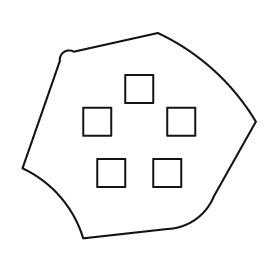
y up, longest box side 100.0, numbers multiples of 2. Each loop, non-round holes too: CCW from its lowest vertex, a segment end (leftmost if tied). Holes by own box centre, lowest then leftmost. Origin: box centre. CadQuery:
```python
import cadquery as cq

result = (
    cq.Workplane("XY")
    .moveTo(-24.0, -44.0)
    .lineTo(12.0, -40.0)
    .threePointArc((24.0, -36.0), (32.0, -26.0))
    .lineTo(50.0, 6.0)
    .threePointArc((32.0, 28.0), (8.0, 44.0))
    .lineTo(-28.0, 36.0)
    .threePointArc((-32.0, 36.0), (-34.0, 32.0))
    .lineTo(-50.0, -14.0)
    .threePointArc((-34.0, -26.0), (-24.0, -44.0))
    .close()
    .moveTo(-18.0, -22.0)
    .lineTo(-6.0, -22.0)
    .lineTo(-6.0, -10.0)
    .lineTo(-18.0, -10.0)
    .close()
    .moveTo(6.0, -22.0)
    .lineTo(18.0, -22.0)
    .lineTo(18.0, -10.0)
    .lineTo(6.0, -10.0)
    .close()
    .moveTo(-24.0, 0.0)
    .lineTo(-12.0, 0.0)
    .lineTo(-12.0, 12.0)
    .lineTo(-24.0, 12.0)
    .close()
    .moveTo(12.0, 0.0)
    .lineTo(24.0, 0.0)
    .lineTo(24.0, 12.0)
    .lineTo(12.0, 12.0)
    .close()
    .moveTo(-6.0, 14.0)
    .lineTo(6.0, 14.0)
    .lineTo(6.0, 26.0)
    .lineTo(-6.0, 26.0)
    .close()
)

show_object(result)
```